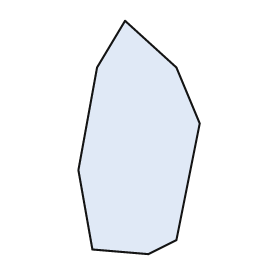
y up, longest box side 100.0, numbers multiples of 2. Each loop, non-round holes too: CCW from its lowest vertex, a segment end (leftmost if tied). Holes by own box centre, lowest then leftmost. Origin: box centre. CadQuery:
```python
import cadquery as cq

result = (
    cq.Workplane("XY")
    .moveTo(4.0, -50.0)
    .lineTo(16.0, -44.0)
    .lineTo(26.0, 6.0)
    .lineTo(16.0, 30.0)
    .lineTo(-6.0, 50.0)
    .lineTo(-18.0, 30.0)
    .lineTo(-26.0, -14.0)
    .lineTo(-20.0, -48.0)
    .close()
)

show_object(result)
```